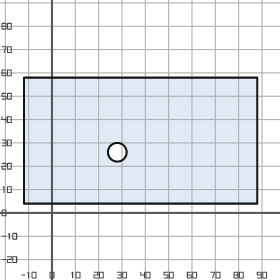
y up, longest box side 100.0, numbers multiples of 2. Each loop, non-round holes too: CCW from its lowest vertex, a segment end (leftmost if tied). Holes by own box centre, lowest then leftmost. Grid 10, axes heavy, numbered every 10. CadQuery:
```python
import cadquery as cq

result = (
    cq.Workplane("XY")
    .moveTo(-12.0, 4.0)
    .lineTo(88.0, 4.0)
    .lineTo(88.0, 58.0)
    .lineTo(-12.0, 58.0)
    .close()
    .moveTo(28.0, 26.0)
    .circle(4.0)
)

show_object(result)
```